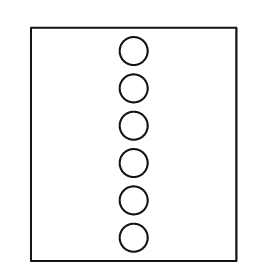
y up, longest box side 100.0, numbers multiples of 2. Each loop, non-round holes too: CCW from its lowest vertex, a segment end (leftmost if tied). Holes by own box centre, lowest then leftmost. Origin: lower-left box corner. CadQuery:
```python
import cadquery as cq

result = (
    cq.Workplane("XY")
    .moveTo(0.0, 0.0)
    .lineTo(88.0, 0.0)
    .lineTo(88.0, 100.0)
    .lineTo(0.0, 100.0)
    .close()
    .moveTo(44.0, 10.0)
    .circle(6.0)
    .moveTo(44.0, 26.0)
    .circle(6.0)
    .moveTo(44.0, 42.0)
    .circle(6.0)
    .moveTo(44.0, 58.0)
    .circle(6.0)
    .moveTo(44.0, 74.0)
    .circle(6.0)
    .moveTo(44.0, 90.0)
    .circle(6.0)
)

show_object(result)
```